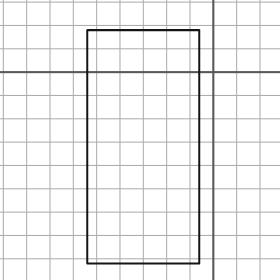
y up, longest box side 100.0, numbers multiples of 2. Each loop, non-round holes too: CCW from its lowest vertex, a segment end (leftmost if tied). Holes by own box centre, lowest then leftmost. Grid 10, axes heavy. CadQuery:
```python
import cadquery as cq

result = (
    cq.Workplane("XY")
    .moveTo(-54.0, -82.0)
    .lineTo(-6.0, -82.0)
    .lineTo(-6.0, 18.0)
    .lineTo(-54.0, 18.0)
    .close()
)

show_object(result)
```